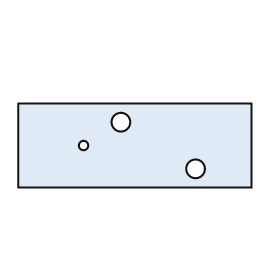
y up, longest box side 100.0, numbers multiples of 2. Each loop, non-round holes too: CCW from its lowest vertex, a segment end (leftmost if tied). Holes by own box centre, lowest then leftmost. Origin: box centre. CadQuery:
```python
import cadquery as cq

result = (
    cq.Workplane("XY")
    .moveTo(-50.0, -18.0)
    .lineTo(50.0, -18.0)
    .lineTo(50.0, 18.0)
    .lineTo(-50.0, 18.0)
    .close()
    .moveTo(26.0, -10.0)
    .circle(4.0)
    .moveTo(-22.0, 0.0)
    .circle(2.0)
    .moveTo(-6.0, 10.0)
    .circle(4.0)
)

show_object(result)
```